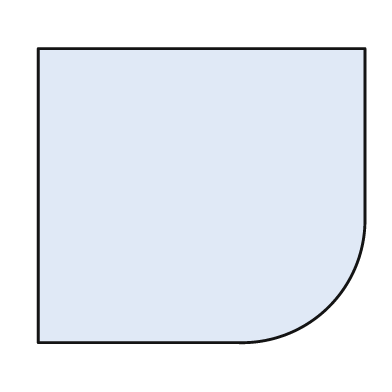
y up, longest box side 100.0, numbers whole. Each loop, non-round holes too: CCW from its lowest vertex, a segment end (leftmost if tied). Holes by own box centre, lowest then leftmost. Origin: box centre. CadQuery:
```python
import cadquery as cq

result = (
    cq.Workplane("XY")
    .moveTo(-50.0, -45.0)
    .lineTo(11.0, -45.0)
    .threePointArc((39.0, -34.0), (50.0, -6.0))
    .lineTo(50.0, 45.0)
    .lineTo(-50.0, 45.0)
    .close()
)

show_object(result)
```